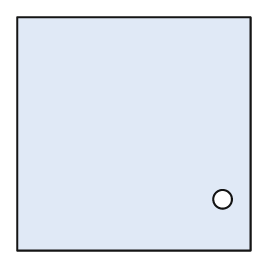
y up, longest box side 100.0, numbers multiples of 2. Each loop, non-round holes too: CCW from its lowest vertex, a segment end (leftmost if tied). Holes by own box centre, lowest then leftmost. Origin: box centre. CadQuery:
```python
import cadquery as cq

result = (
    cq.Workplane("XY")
    .moveTo(-50.0, -50.0)
    .lineTo(50.0, -50.0)
    .lineTo(50.0, 50.0)
    .lineTo(-50.0, 50.0)
    .close()
    .moveTo(38.0, -28.0)
    .circle(4.0)
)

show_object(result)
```